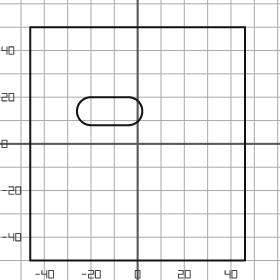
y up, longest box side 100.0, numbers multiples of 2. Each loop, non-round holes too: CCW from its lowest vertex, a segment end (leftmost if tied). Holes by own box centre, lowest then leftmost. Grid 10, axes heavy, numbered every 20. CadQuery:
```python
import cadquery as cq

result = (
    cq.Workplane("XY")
    .moveTo(-46.0, -50.0)
    .lineTo(46.0, -50.0)
    .lineTo(46.0, 50.0)
    .lineTo(-46.0, 50.0)
    .close()
    .moveTo(-20.0, 8.0)
    .lineTo(-4.0, 8.0)
    .threePointArc((2.0, 14.0), (-4.0, 20.0))
    .lineTo(-20.0, 20.0)
    .threePointArc((-26.0, 14.0), (-20.0, 8.0))
    .close()
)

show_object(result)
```